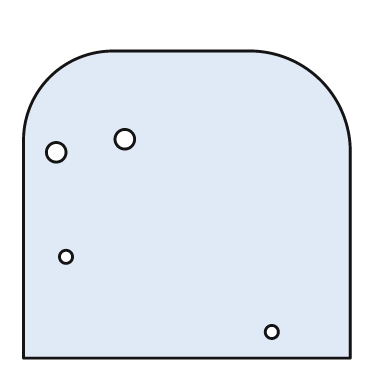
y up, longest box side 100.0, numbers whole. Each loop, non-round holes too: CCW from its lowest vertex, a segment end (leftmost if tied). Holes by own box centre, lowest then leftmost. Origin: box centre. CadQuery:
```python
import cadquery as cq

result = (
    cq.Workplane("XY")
    .moveTo(-50.0, -47.0)
    .lineTo(50.0, -47.0)
    .lineTo(50.0, 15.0)
    .threePointArc((41.0, 38.0), (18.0, 47.0))
    .lineTo(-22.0, 47.0)
    .threePointArc((-42.0, 39.0), (-50.0, 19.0))
    .close()
    .moveTo(26.0, -39.0)
    .circle(2.0)
    .moveTo(-37.0, -16.0)
    .circle(2.0)
    .moveTo(-40.0, 16.0)
    .circle(3.0)
    .moveTo(-19.0, 20.0)
    .circle(3.0)
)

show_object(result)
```